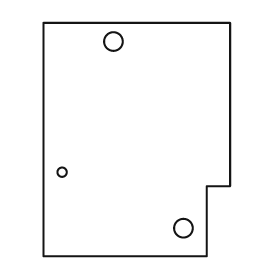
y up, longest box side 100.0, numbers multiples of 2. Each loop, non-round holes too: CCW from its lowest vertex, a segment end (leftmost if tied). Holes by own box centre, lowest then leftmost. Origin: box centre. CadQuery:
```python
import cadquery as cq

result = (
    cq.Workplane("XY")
    .moveTo(-40.0, -50.0)
    .lineTo(30.0, -50.0)
    .lineTo(30.0, -20.0)
    .lineTo(40.0, -20.0)
    .lineTo(40.0, 50.0)
    .lineTo(-40.0, 50.0)
    .close()
    .moveTo(20.0, -38.0)
    .circle(4.0)
    .moveTo(-32.0, -14.0)
    .circle(2.0)
    .moveTo(-10.0, 42.0)
    .circle(4.0)
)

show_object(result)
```